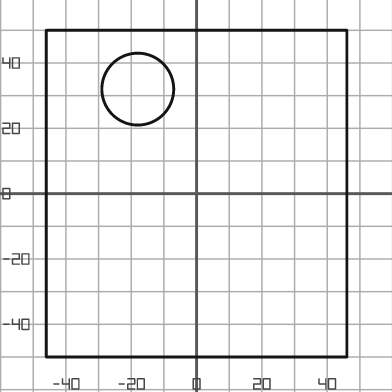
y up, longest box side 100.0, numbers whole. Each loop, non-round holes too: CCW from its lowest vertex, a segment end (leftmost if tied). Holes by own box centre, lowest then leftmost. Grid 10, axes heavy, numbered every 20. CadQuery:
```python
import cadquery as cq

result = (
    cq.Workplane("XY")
    .moveTo(-46.0, -50.0)
    .lineTo(46.0, -50.0)
    .lineTo(46.0, 50.0)
    .lineTo(-46.0, 50.0)
    .close()
    .moveTo(-18.0, 32.0)
    .circle(11.0)
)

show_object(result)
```